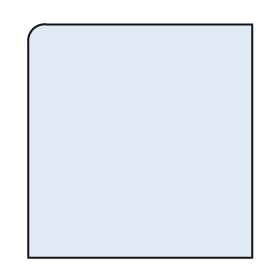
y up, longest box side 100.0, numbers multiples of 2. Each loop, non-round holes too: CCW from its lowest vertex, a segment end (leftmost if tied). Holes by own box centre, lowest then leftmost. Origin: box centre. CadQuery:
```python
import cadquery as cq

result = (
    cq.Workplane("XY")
    .moveTo(-48.0, -50.0)
    .lineTo(48.0, -50.0)
    .lineTo(48.0, 50.0)
    .lineTo(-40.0, 50.0)
    .threePointArc((-46.0, 48.0), (-48.0, 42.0))
    .close()
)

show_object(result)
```